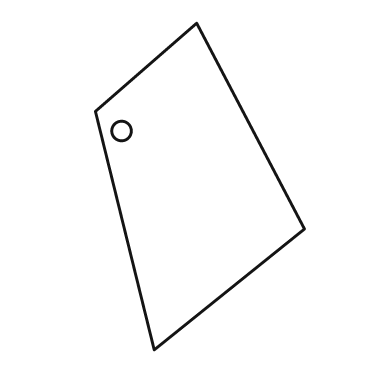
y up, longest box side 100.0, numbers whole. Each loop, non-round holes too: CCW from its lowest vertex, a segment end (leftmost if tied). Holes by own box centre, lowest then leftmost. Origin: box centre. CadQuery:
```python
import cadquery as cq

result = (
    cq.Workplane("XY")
    .moveTo(-14.0, -50.0)
    .lineTo(32.0, -13.0)
    .lineTo(-1.0, 50.0)
    .lineTo(-32.0, 23.0)
    .close()
    .moveTo(-24.0, 17.0)
    .circle(3.0)
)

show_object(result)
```